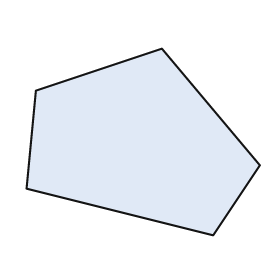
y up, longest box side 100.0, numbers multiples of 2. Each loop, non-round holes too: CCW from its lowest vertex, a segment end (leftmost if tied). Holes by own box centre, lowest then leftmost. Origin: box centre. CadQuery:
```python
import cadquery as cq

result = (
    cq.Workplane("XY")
    .moveTo(30.0, -40.0)
    .lineTo(50.0, -10.0)
    .lineTo(8.0, 40.0)
    .lineTo(-46.0, 22.0)
    .lineTo(-50.0, -20.0)
    .close()
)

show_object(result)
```